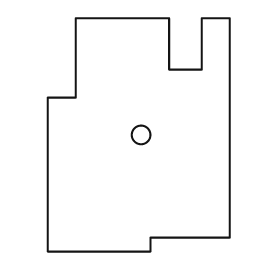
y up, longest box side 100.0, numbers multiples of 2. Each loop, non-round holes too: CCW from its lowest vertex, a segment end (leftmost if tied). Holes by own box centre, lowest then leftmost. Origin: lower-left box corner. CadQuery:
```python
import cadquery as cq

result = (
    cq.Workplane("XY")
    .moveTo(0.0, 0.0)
    .lineTo(44.0, 0.0)
    .lineTo(44.0, 6.0)
    .lineTo(78.0, 6.0)
    .lineTo(78.0, 100.0)
    .lineTo(66.0, 100.0)
    .lineTo(66.0, 78.0)
    .lineTo(52.0, 78.0)
    .lineTo(52.0, 100.0)
    .lineTo(12.0, 100.0)
    .lineTo(12.0, 66.0)
    .lineTo(0.0, 66.0)
    .close()
    .moveTo(40.0, 50.0)
    .circle(4.0)
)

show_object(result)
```